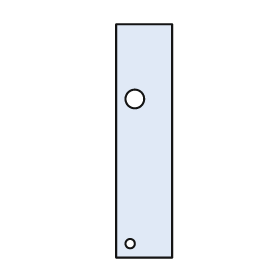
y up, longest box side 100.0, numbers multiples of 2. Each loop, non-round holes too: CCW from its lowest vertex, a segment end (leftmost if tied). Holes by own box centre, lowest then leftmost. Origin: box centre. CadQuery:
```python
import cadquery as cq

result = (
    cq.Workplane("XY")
    .moveTo(-12.0, -50.0)
    .lineTo(12.0, -50.0)
    .lineTo(12.0, 50.0)
    .lineTo(-12.0, 50.0)
    .close()
    .moveTo(-6.0, -44.0)
    .circle(2.0)
    .moveTo(-4.0, 18.0)
    .circle(4.0)
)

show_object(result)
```